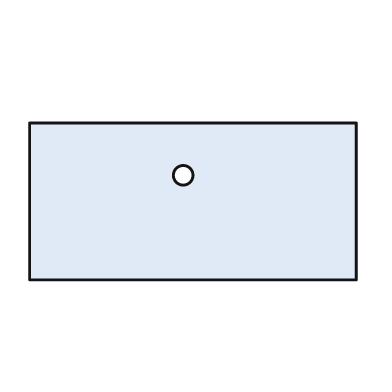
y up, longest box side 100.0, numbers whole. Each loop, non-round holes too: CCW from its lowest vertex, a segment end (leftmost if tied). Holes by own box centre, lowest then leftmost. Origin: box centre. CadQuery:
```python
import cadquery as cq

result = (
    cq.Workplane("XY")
    .moveTo(-50.0, -24.0)
    .lineTo(50.0, -24.0)
    .lineTo(50.0, 24.0)
    .lineTo(-50.0, 24.0)
    .close()
    .moveTo(-3.0, 8.0)
    .circle(3.0)
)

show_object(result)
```